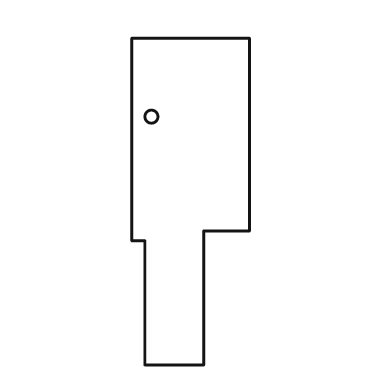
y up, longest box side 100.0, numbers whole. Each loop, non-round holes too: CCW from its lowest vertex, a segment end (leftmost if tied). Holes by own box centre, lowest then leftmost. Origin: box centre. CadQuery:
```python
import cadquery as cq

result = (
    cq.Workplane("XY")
    .moveTo(-14.0, -50.0)
    .lineTo(4.0, -50.0)
    .lineTo(4.0, -9.0)
    .lineTo(18.0, -9.0)
    .lineTo(18.0, 50.0)
    .lineTo(-18.0, 50.0)
    .lineTo(-18.0, -12.0)
    .lineTo(-14.0, -12.0)
    .close()
    .moveTo(-12.0, 26.0)
    .circle(2.0)
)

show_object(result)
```